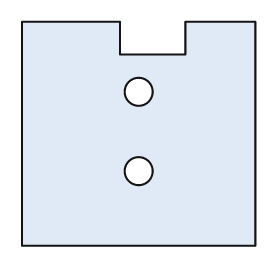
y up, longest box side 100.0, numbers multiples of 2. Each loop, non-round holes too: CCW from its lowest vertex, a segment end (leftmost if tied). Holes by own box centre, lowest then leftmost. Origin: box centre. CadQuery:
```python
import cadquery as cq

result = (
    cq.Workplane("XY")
    .moveTo(-50.0, -48.0)
    .lineTo(50.0, -48.0)
    .lineTo(50.0, 48.0)
    .lineTo(20.0, 48.0)
    .lineTo(20.0, 34.0)
    .lineTo(-8.0, 34.0)
    .lineTo(-8.0, 48.0)
    .lineTo(-50.0, 48.0)
    .close()
    .moveTo(0.0, -16.0)
    .circle(6.0)
    .moveTo(0.0, 18.0)
    .circle(6.0)
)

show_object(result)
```